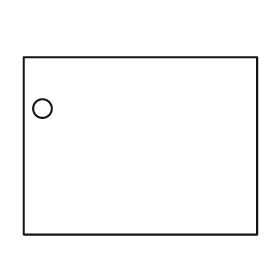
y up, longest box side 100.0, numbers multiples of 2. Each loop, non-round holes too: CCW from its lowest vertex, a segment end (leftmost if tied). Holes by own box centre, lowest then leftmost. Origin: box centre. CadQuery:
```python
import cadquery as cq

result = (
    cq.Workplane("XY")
    .moveTo(-50.0, -38.0)
    .lineTo(50.0, -38.0)
    .lineTo(50.0, 38.0)
    .lineTo(-50.0, 38.0)
    .close()
    .moveTo(-42.0, 16.0)
    .circle(4.0)
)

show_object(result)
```